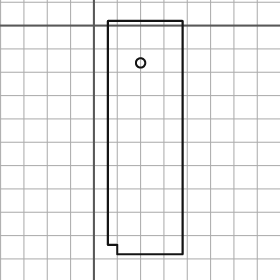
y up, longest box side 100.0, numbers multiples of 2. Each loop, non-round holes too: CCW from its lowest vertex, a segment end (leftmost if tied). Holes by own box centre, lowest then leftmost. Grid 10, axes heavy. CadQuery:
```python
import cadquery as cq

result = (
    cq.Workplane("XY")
    .moveTo(10.0, -98.0)
    .lineTo(38.0, -98.0)
    .lineTo(38.0, 2.0)
    .lineTo(6.0, 2.0)
    .lineTo(6.0, -94.0)
    .lineTo(10.0, -94.0)
    .close()
    .moveTo(20.0, -16.0)
    .circle(2.0)
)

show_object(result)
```